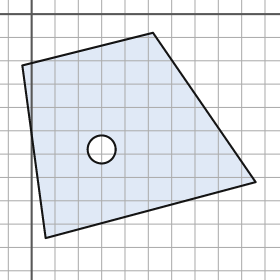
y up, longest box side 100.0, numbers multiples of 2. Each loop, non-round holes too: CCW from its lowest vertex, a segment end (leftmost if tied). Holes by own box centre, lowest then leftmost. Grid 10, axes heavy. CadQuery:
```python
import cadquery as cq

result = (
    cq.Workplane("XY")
    .moveTo(6.0, -96.0)
    .lineTo(96.0, -72.0)
    .lineTo(52.0, -8.0)
    .lineTo(-4.0, -22.0)
    .close()
    .moveTo(30.0, -58.0)
    .circle(6.0)
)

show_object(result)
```